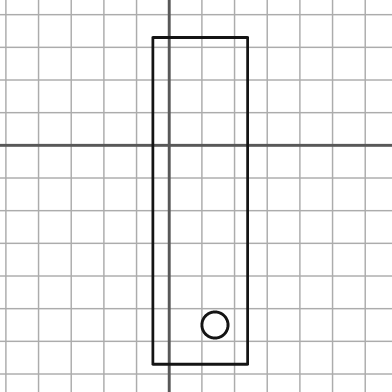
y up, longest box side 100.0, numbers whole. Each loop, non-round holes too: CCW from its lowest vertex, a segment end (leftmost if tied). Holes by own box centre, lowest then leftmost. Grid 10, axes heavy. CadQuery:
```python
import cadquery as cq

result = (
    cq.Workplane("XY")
    .moveTo(-5.0, -67.0)
    .lineTo(24.0, -67.0)
    .lineTo(24.0, 33.0)
    .lineTo(-5.0, 33.0)
    .close()
    .moveTo(14.0, -55.0)
    .circle(4.0)
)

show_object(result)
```